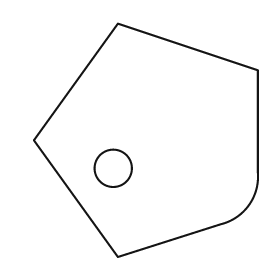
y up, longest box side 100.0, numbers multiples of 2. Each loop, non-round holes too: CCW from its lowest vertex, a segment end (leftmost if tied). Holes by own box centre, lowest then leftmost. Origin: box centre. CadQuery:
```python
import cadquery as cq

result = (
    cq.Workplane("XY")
    .moveTo(-12.0, -50.0)
    .lineTo(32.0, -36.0)
    .threePointArc((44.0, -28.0), (48.0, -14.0))
    .lineTo(48.0, 30.0)
    .lineTo(-12.0, 50.0)
    .lineTo(-48.0, 0.0)
    .close()
    .moveTo(-14.0, -12.0)
    .circle(8.0)
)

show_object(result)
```